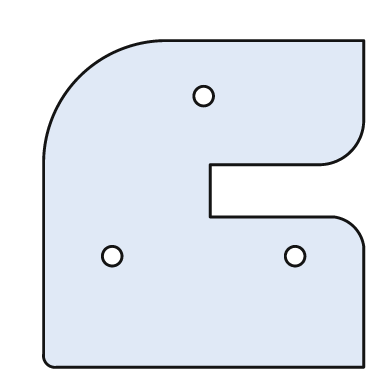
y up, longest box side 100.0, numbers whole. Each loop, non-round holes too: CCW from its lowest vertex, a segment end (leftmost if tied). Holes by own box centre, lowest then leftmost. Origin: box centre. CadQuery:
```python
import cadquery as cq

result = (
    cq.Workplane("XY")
    .moveTo(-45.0, -50.0)
    .lineTo(49.0, -50.0)
    .lineTo(49.0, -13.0)
    .threePointArc((46.0, -7.0), (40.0, -4.0))
    .lineTo(2.0, -4.0)
    .lineTo(2.0, 12.0)
    .lineTo(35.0, 12.0)
    .threePointArc((45.0, 16.0), (49.0, 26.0))
    .lineTo(49.0, 50.0)
    .lineTo(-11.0, 50.0)
    .threePointArc((-38.0, 39.0), (-49.0, 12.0))
    .lineTo(-49.0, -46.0)
    .threePointArc((-48.0, -49.0), (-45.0, -50.0))
    .close()
    .moveTo(-28.0, -16.0)
    .circle(3.0)
    .moveTo(28.0, -16.0)
    .circle(3.0)
    .moveTo(0.0, 33.0)
    .circle(3.0)
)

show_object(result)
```